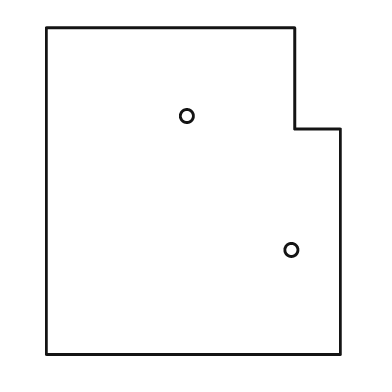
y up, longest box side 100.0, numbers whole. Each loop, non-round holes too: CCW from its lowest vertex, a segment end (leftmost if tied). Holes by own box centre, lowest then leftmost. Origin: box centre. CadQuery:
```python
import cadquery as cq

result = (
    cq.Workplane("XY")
    .moveTo(-45.0, -50.0)
    .lineTo(45.0, -50.0)
    .lineTo(45.0, 19.0)
    .lineTo(31.0, 19.0)
    .lineTo(31.0, 50.0)
    .lineTo(-45.0, 50.0)
    .close()
    .moveTo(30.0, -18.0)
    .circle(2.0)
    .moveTo(-2.0, 23.0)
    .circle(2.0)
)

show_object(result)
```